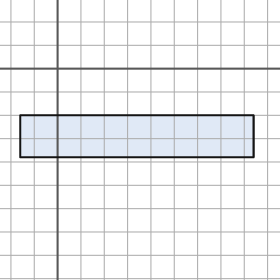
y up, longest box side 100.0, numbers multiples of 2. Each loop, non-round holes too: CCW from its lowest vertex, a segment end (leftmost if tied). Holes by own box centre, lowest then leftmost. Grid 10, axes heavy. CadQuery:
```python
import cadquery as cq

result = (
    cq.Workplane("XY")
    .moveTo(-16.0, -38.0)
    .lineTo(84.0, -38.0)
    .lineTo(84.0, -20.0)
    .lineTo(-16.0, -20.0)
    .close()
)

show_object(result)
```